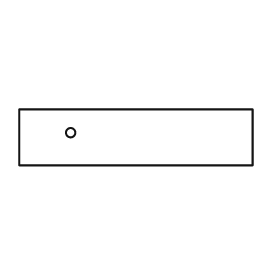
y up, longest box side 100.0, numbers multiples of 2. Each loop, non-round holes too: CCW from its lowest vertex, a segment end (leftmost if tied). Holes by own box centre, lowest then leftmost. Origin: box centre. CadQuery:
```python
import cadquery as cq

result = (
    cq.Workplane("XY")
    .moveTo(-50.0, -12.0)
    .lineTo(50.0, -12.0)
    .lineTo(50.0, 12.0)
    .lineTo(-50.0, 12.0)
    .close()
    .moveTo(-28.0, 2.0)
    .circle(2.0)
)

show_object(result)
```